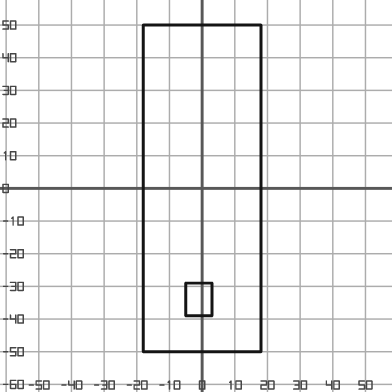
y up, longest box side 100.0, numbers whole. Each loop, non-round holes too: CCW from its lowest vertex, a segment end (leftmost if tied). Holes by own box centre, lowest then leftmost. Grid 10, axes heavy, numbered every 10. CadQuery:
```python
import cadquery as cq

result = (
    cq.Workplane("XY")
    .moveTo(-18.0, -50.0)
    .lineTo(18.0, -50.0)
    .lineTo(18.0, 50.0)
    .lineTo(-18.0, 50.0)
    .close()
    .moveTo(-5.0, -39.0)
    .lineTo(3.0, -39.0)
    .lineTo(3.0, -29.0)
    .lineTo(-5.0, -29.0)
    .close()
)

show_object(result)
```